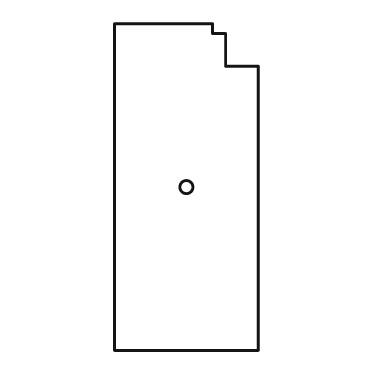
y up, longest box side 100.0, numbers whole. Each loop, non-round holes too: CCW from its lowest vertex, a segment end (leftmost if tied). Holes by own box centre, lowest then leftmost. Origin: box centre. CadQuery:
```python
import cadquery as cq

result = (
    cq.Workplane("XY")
    .moveTo(-22.0, -50.0)
    .lineTo(22.0, -50.0)
    .lineTo(22.0, 37.0)
    .lineTo(12.0, 37.0)
    .lineTo(12.0, 47.0)
    .lineTo(8.0, 47.0)
    .lineTo(8.0, 50.0)
    .lineTo(-22.0, 50.0)
    .close()
    .moveTo(0.0, 0.0)
    .circle(2.0)
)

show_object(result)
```